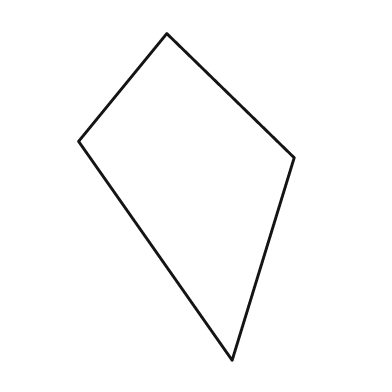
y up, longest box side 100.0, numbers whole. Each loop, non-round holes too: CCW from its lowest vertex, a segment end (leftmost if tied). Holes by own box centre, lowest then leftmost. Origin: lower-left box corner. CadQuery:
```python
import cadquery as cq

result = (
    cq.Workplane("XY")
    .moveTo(47.0, 0.0)
    .lineTo(66.0, 62.0)
    .lineTo(27.0, 100.0)
    .lineTo(0.0, 67.0)
    .close()
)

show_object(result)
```